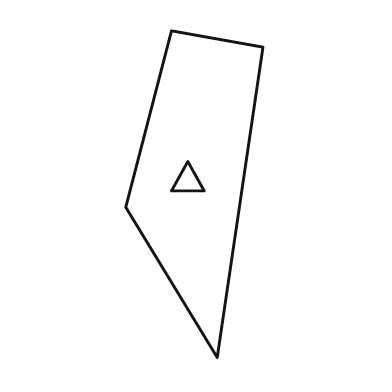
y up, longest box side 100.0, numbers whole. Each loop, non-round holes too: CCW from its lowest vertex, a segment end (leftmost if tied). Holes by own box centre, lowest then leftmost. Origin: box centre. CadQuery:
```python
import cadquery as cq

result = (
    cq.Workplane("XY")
    .moveTo(7.0, -50.0)
    .lineTo(21.0, 45.0)
    .lineTo(-7.0, 50.0)
    .lineTo(-21.0, -4.0)
    .close()
    .moveTo(-7.0, 1.0)
    .lineTo(3.0, 1.0)
    .lineTo(-2.0, 10.0)
    .close()
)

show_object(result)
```